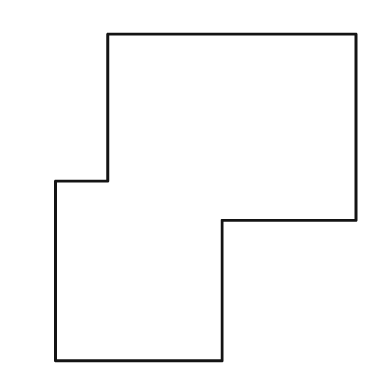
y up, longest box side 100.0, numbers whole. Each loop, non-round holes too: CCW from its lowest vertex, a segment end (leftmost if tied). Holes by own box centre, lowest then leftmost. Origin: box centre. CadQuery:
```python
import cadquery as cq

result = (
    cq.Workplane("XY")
    .moveTo(-46.0, -50.0)
    .lineTo(5.0, -50.0)
    .lineTo(5.0, -7.0)
    .lineTo(46.0, -7.0)
    .lineTo(46.0, 50.0)
    .lineTo(-30.0, 50.0)
    .lineTo(-30.0, 5.0)
    .lineTo(-46.0, 5.0)
    .close()
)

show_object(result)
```